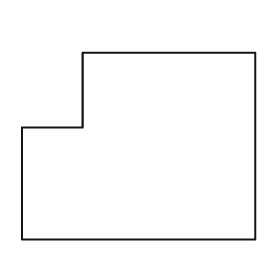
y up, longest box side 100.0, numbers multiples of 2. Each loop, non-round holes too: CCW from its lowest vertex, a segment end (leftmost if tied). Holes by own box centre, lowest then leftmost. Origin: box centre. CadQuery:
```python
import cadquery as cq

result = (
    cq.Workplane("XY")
    .moveTo(-50.0, -40.0)
    .lineTo(50.0, -40.0)
    .lineTo(50.0, 40.0)
    .lineTo(-24.0, 40.0)
    .lineTo(-24.0, 8.0)
    .lineTo(-50.0, 8.0)
    .close()
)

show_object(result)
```